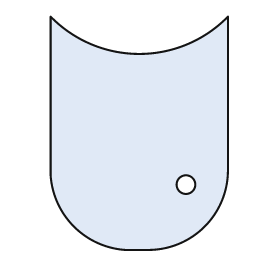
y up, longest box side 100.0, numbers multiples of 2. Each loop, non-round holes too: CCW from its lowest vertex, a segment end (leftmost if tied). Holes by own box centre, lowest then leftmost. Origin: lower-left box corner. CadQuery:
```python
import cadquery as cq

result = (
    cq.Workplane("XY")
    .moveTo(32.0, 0.0)
    .lineTo(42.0, 0.0)
    .threePointArc((66.0, 10.0), (76.0, 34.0))
    .lineTo(76.0, 100.0)
    .threePointArc((38.0, 84.0), (0.0, 100.0))
    .lineTo(0.0, 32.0)
    .threePointArc((10.0, 10.0), (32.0, 0.0))
    .close()
    .moveTo(58.0, 28.0)
    .circle(4.0)
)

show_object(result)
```